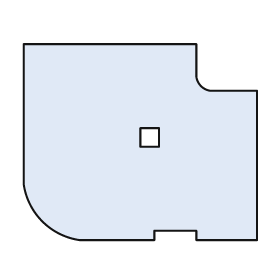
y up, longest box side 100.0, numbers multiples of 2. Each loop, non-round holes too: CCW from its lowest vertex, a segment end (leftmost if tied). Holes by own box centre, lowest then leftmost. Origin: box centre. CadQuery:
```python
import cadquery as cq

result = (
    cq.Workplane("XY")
    .moveTo(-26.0, -42.0)
    .lineTo(6.0, -42.0)
    .lineTo(6.0, -38.0)
    .lineTo(24.0, -38.0)
    .lineTo(24.0, -42.0)
    .lineTo(50.0, -42.0)
    .lineTo(50.0, 22.0)
    .lineTo(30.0, 22.0)
    .threePointArc((26.0, 24.0), (24.0, 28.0))
    .lineTo(24.0, 42.0)
    .lineTo(-50.0, 42.0)
    .lineTo(-50.0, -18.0)
    .threePointArc((-42.0, -34.0), (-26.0, -42.0))
    .close()
    .moveTo(0.0, -2.0)
    .lineTo(8.0, -2.0)
    .lineTo(8.0, 6.0)
    .lineTo(0.0, 6.0)
    .close()
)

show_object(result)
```